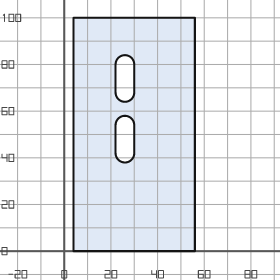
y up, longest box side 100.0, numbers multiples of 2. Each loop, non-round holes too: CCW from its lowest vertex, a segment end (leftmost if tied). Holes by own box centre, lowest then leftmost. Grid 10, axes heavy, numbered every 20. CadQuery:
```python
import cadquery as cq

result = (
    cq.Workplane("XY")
    .moveTo(4.0, 0.0)
    .lineTo(56.0, 0.0)
    .lineTo(56.0, 100.0)
    .lineTo(4.0, 100.0)
    .close()
    .moveTo(22.0, 42.0)
    .threePointArc((26.0, 38.0), (30.0, 42.0))
    .lineTo(30.0, 54.0)
    .threePointArc((26.0, 58.0), (22.0, 54.0))
    .close()
    .moveTo(22.0, 68.0)
    .threePointArc((26.0, 64.0), (30.0, 68.0))
    .lineTo(30.0, 80.0)
    .threePointArc((26.0, 84.0), (22.0, 80.0))
    .close()
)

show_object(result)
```